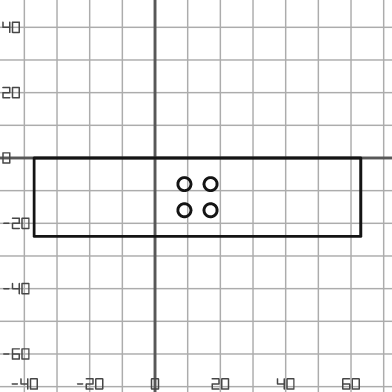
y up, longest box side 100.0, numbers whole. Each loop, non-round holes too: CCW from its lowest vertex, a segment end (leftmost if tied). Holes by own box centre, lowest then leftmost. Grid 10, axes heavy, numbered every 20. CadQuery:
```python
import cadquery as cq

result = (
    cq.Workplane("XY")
    .moveTo(-37.0, -24.0)
    .lineTo(63.0, -24.0)
    .lineTo(63.0, 0.0)
    .lineTo(-37.0, 0.0)
    .close()
    .moveTo(9.0, -16.0)
    .circle(2.0)
    .moveTo(17.0, -16.0)
    .circle(2.0)
    .moveTo(9.0, -8.0)
    .circle(2.0)
    .moveTo(17.0, -8.0)
    .circle(2.0)
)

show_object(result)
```